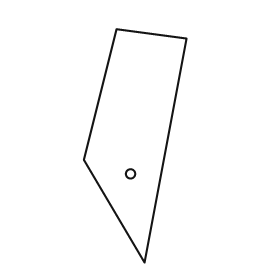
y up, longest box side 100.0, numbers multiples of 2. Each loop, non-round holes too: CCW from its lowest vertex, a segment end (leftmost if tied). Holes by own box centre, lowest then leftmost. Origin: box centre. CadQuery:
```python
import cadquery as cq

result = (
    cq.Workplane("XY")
    .moveTo(4.0, -50.0)
    .lineTo(22.0, 46.0)
    .lineTo(-8.0, 50.0)
    .lineTo(-22.0, -6.0)
    .close()
    .moveTo(-2.0, -12.0)
    .circle(2.0)
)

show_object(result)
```